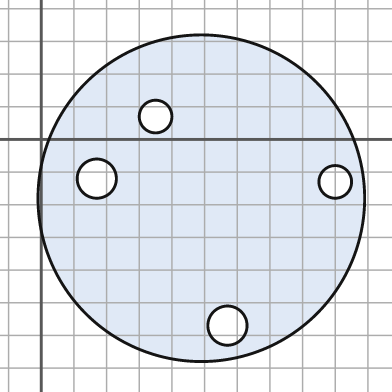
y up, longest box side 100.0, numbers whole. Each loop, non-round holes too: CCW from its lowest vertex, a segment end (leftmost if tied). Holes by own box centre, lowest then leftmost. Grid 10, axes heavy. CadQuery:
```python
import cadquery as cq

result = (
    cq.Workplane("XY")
    .moveTo(49.0, -18.0)
    .circle(50.0)
    .moveTo(57.0, -57.0)
    .circle(6.0)
    .moveTo(90.0, -13.0)
    .circle(5.0)
    .moveTo(17.0, -12.0)
    .circle(6.0)
    .moveTo(35.0, 7.0)
    .circle(5.0)
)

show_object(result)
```